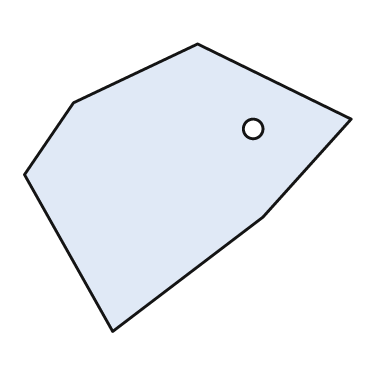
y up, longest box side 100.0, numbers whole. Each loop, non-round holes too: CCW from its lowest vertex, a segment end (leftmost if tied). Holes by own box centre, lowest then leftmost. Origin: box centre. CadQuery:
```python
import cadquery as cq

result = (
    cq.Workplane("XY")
    .moveTo(-23.0, -44.0)
    .lineTo(23.0, -9.0)
    .lineTo(50.0, 21.0)
    .lineTo(3.0, 44.0)
    .lineTo(-35.0, 26.0)
    .lineTo(-50.0, 4.0)
    .close()
    .moveTo(20.0, 18.0)
    .circle(3.0)
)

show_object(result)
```